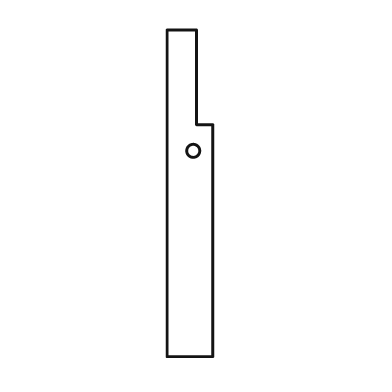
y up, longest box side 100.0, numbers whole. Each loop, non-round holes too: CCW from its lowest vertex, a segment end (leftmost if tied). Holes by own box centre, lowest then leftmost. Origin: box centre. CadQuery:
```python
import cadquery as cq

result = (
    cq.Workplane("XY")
    .moveTo(-7.0, -50.0)
    .lineTo(7.0, -50.0)
    .lineTo(7.0, 21.0)
    .lineTo(2.0, 21.0)
    .lineTo(2.0, 50.0)
    .lineTo(-7.0, 50.0)
    .close()
    .moveTo(1.0, 13.0)
    .circle(2.0)
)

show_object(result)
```